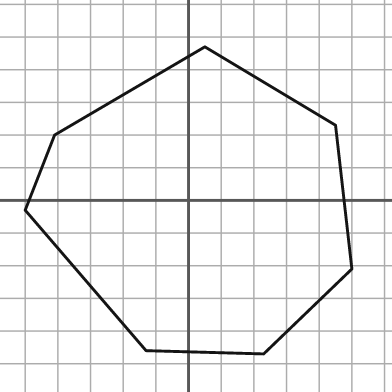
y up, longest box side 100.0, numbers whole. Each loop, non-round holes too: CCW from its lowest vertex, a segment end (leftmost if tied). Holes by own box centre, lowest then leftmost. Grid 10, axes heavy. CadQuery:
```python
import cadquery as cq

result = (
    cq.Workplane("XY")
    .moveTo(23.0, -47.0)
    .lineTo(50.0, -21.0)
    .lineTo(45.0, 23.0)
    .lineTo(5.0, 47.0)
    .lineTo(-41.0, 20.0)
    .lineTo(-50.0, -3.0)
    .lineTo(-13.0, -46.0)
    .close()
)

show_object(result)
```